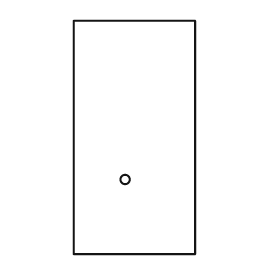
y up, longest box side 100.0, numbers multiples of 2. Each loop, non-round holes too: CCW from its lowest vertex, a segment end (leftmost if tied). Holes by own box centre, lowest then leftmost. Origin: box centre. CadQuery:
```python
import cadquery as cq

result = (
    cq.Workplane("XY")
    .moveTo(-26.0, -50.0)
    .lineTo(26.0, -50.0)
    .lineTo(26.0, 50.0)
    .lineTo(-26.0, 50.0)
    .close()
    .moveTo(-4.0, -18.0)
    .circle(2.0)
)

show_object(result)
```